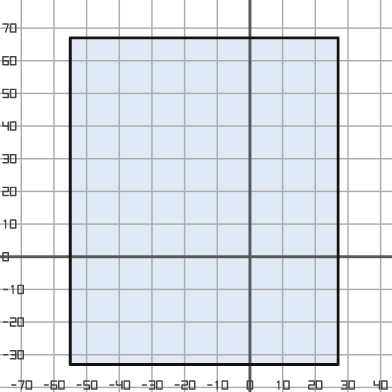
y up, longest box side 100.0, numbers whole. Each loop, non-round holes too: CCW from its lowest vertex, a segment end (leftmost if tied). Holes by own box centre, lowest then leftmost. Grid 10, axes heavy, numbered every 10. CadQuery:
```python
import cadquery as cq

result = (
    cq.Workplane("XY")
    .moveTo(-55.0, -33.0)
    .lineTo(27.0, -33.0)
    .lineTo(27.0, 67.0)
    .lineTo(-55.0, 67.0)
    .close()
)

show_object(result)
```